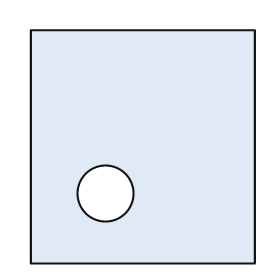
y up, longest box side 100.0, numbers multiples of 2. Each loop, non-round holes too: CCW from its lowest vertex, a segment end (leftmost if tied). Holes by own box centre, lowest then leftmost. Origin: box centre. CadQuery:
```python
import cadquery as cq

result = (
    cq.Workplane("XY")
    .moveTo(-48.0, -50.0)
    .lineTo(48.0, -50.0)
    .lineTo(48.0, 50.0)
    .lineTo(-48.0, 50.0)
    .close()
    .moveTo(-16.0, -20.0)
    .circle(12.0)
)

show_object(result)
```